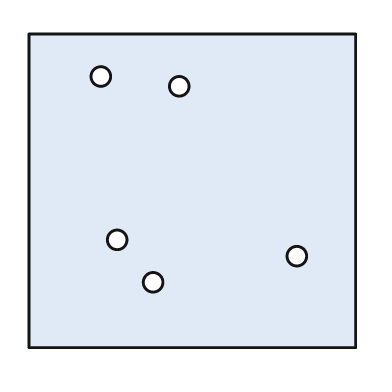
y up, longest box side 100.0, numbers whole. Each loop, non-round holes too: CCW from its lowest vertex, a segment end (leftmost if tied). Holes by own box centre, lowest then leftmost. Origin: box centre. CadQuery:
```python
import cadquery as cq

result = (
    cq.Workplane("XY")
    .moveTo(-50.0, -48.0)
    .lineTo(50.0, -48.0)
    .lineTo(50.0, 48.0)
    .lineTo(-50.0, 48.0)
    .close()
    .moveTo(-12.0, -28.0)
    .circle(3.0)
    .moveTo(32.0, -20.0)
    .circle(3.0)
    .moveTo(-23.0, -15.0)
    .circle(3.0)
    .moveTo(-4.0, 32.0)
    .circle(3.0)
    .moveTo(-28.0, 35.0)
    .circle(3.0)
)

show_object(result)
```